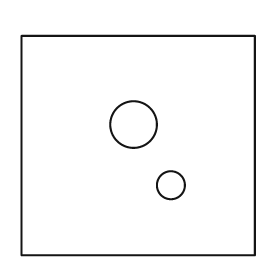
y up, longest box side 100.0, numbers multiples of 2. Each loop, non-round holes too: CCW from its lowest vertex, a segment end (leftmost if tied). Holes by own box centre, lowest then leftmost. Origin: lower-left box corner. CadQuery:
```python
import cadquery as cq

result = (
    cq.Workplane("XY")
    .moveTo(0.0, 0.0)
    .lineTo(100.0, 0.0)
    .lineTo(100.0, 94.0)
    .lineTo(0.0, 94.0)
    .close()
    .moveTo(64.0, 30.0)
    .circle(6.0)
    .moveTo(48.0, 56.0)
    .circle(10.0)
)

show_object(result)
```